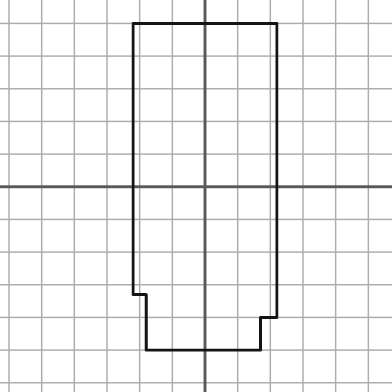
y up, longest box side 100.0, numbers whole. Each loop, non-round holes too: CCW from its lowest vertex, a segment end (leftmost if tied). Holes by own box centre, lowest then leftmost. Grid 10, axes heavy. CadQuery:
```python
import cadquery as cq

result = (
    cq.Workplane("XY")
    .moveTo(-18.0, -50.0)
    .lineTo(17.0, -50.0)
    .lineTo(17.0, -40.0)
    .lineTo(22.0, -40.0)
    .lineTo(22.0, 50.0)
    .lineTo(-22.0, 50.0)
    .lineTo(-22.0, -33.0)
    .lineTo(-18.0, -33.0)
    .close()
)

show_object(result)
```